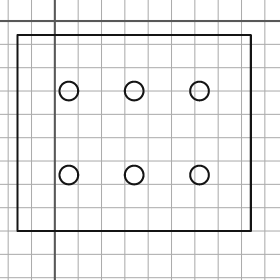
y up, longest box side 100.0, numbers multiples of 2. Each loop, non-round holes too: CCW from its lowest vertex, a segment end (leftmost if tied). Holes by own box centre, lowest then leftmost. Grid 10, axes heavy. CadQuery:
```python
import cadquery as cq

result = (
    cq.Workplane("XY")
    .moveTo(-16.0, -90.0)
    .lineTo(84.0, -90.0)
    .lineTo(84.0, -6.0)
    .lineTo(-16.0, -6.0)
    .close()
    .moveTo(6.0, -66.0)
    .circle(4.0)
    .moveTo(34.0, -66.0)
    .circle(4.0)
    .moveTo(62.0, -66.0)
    .circle(4.0)
    .moveTo(6.0, -30.0)
    .circle(4.0)
    .moveTo(34.0, -30.0)
    .circle(4.0)
    .moveTo(62.0, -30.0)
    .circle(4.0)
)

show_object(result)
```